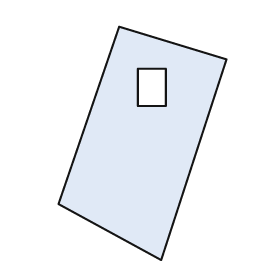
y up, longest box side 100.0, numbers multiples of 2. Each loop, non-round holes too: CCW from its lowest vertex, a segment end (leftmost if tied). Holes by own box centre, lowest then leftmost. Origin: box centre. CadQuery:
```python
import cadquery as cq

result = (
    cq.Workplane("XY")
    .moveTo(8.0, -50.0)
    .lineTo(36.0, 36.0)
    .lineTo(-10.0, 50.0)
    .lineTo(-36.0, -26.0)
    .close()
    .moveTo(-2.0, 16.0)
    .lineTo(10.0, 16.0)
    .lineTo(10.0, 32.0)
    .lineTo(-2.0, 32.0)
    .close()
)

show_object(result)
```